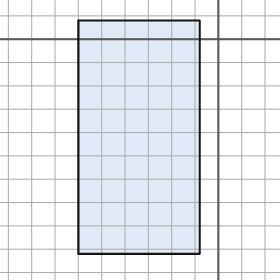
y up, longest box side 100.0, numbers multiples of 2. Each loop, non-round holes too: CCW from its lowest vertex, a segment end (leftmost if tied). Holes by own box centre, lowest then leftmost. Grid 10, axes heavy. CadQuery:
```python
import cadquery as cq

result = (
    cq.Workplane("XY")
    .moveTo(-60.0, -92.0)
    .lineTo(-8.0, -92.0)
    .lineTo(-8.0, 8.0)
    .lineTo(-60.0, 8.0)
    .close()
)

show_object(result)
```